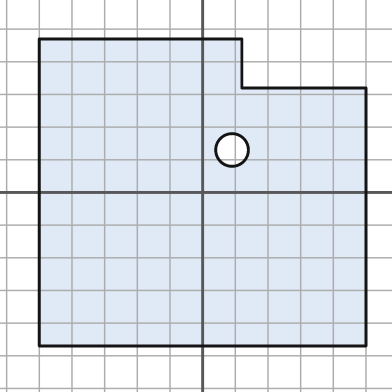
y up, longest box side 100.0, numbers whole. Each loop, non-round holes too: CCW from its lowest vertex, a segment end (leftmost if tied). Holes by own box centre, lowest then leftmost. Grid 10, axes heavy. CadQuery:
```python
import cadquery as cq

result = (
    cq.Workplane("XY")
    .moveTo(-50.0, -47.0)
    .lineTo(50.0, -47.0)
    .lineTo(50.0, 32.0)
    .lineTo(12.0, 32.0)
    .lineTo(12.0, 47.0)
    .lineTo(-50.0, 47.0)
    .close()
    .moveTo(9.0, 13.0)
    .circle(5.0)
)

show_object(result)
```